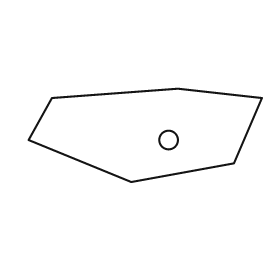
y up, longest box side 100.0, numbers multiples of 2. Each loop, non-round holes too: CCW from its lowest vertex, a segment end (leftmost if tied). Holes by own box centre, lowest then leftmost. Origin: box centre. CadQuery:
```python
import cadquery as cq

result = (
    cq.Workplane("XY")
    .moveTo(-6.0, -20.0)
    .lineTo(38.0, -12.0)
    .lineTo(50.0, 16.0)
    .lineTo(14.0, 20.0)
    .lineTo(-40.0, 16.0)
    .lineTo(-50.0, -2.0)
    .close()
    .moveTo(10.0, -2.0)
    .circle(4.0)
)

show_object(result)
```